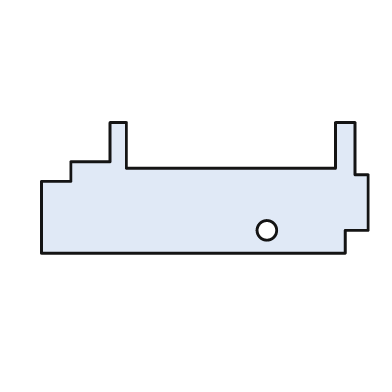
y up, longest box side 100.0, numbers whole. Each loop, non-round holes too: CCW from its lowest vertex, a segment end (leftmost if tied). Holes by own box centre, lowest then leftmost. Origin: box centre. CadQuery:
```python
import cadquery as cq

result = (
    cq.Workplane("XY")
    .moveTo(-50.0, -20.0)
    .lineTo(43.0, -20.0)
    .lineTo(43.0, -13.0)
    .lineTo(50.0, -13.0)
    .lineTo(50.0, 4.0)
    .lineTo(46.0, 4.0)
    .lineTo(46.0, 20.0)
    .lineTo(40.0, 20.0)
    .lineTo(40.0, 6.0)
    .lineTo(-24.0, 6.0)
    .lineTo(-24.0, 20.0)
    .lineTo(-29.0, 20.0)
    .lineTo(-29.0, 8.0)
    .lineTo(-41.0, 8.0)
    .lineTo(-41.0, 2.0)
    .lineTo(-50.0, 2.0)
    .close()
    .moveTo(19.0, -13.0)
    .circle(3.0)
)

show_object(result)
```